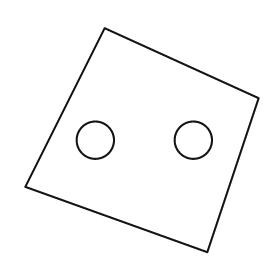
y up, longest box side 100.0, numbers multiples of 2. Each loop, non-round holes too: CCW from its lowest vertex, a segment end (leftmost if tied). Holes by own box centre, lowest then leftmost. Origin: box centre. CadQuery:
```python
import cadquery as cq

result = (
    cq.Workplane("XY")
    .moveTo(28.0, -48.0)
    .lineTo(50.0, 18.0)
    .lineTo(-16.0, 48.0)
    .lineTo(-50.0, -20.0)
    .close()
    .moveTo(-20.0, 0.0)
    .circle(8.0)
    .moveTo(22.0, 0.0)
    .circle(8.0)
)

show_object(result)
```